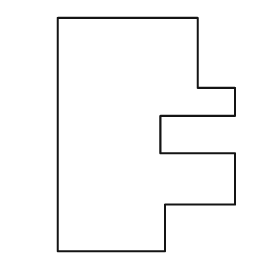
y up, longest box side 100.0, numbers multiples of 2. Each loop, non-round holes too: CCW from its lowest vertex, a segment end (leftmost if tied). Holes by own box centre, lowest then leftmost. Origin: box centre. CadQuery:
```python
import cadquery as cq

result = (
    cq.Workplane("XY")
    .moveTo(-38.0, -50.0)
    .lineTo(8.0, -50.0)
    .lineTo(8.0, -30.0)
    .lineTo(38.0, -30.0)
    .lineTo(38.0, -8.0)
    .lineTo(6.0, -8.0)
    .lineTo(6.0, 8.0)
    .lineTo(38.0, 8.0)
    .lineTo(38.0, 20.0)
    .lineTo(22.0, 20.0)
    .lineTo(22.0, 50.0)
    .lineTo(-38.0, 50.0)
    .close()
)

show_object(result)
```